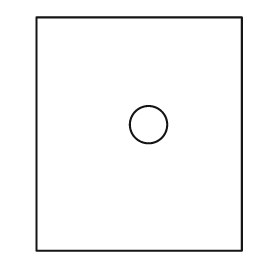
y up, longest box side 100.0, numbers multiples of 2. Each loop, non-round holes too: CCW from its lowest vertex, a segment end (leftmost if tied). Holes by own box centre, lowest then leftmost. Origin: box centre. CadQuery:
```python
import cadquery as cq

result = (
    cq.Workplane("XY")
    .moveTo(-44.0, -50.0)
    .lineTo(44.0, -50.0)
    .lineTo(44.0, 50.0)
    .lineTo(-44.0, 50.0)
    .close()
    .moveTo(4.0, 4.0)
    .circle(8.0)
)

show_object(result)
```